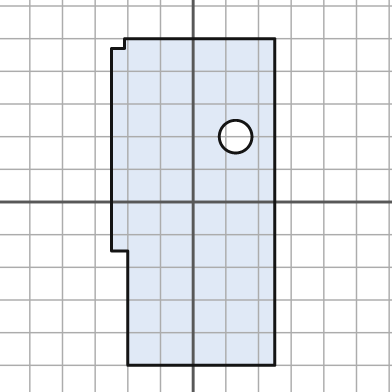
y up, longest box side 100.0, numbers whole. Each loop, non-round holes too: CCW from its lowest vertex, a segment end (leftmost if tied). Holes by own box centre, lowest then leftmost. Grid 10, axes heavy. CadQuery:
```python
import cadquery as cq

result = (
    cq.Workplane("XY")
    .moveTo(-20.0, -50.0)
    .lineTo(25.0, -50.0)
    .lineTo(25.0, 50.0)
    .lineTo(-21.0, 50.0)
    .lineTo(-21.0, 47.0)
    .lineTo(-25.0, 47.0)
    .lineTo(-25.0, -15.0)
    .lineTo(-20.0, -15.0)
    .close()
    .moveTo(13.0, 20.0)
    .circle(5.0)
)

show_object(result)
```